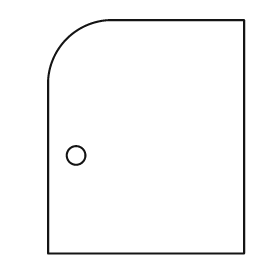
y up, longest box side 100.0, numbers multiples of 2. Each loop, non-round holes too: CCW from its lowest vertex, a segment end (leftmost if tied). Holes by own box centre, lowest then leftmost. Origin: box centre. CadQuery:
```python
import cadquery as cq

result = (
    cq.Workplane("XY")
    .moveTo(-42.0, -50.0)
    .lineTo(42.0, -50.0)
    .lineTo(42.0, 50.0)
    .lineTo(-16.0, 50.0)
    .threePointArc((-34.0, 42.0), (-42.0, 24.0))
    .close()
    .moveTo(-30.0, -8.0)
    .circle(4.0)
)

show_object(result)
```